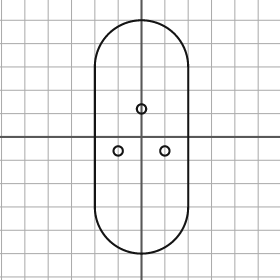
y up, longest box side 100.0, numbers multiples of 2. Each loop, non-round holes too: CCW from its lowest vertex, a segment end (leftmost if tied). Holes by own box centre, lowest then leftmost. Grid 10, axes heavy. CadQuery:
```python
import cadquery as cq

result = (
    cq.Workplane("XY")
    .moveTo(-20.0, -30.0)
    .threePointArc((0.0, -50.0), (20.0, -30.0))
    .lineTo(20.0, 30.0)
    .threePointArc((0.0, 50.0), (-20.0, 30.0))
    .close()
    .moveTo(-10.0, -6.0)
    .circle(2.0)
    .moveTo(10.0, -6.0)
    .circle(2.0)
    .moveTo(0.0, 12.0)
    .circle(2.0)
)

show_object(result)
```